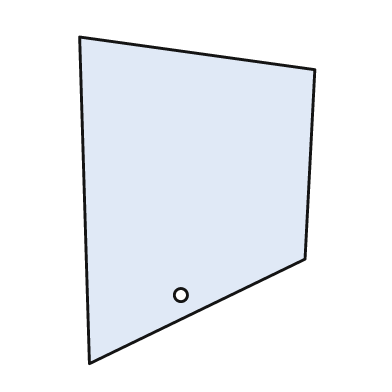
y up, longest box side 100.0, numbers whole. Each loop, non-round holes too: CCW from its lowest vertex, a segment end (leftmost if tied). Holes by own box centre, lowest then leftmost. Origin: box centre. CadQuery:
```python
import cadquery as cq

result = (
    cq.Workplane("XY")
    .moveTo(-33.0, -50.0)
    .lineTo(33.0, -18.0)
    .lineTo(36.0, 40.0)
    .lineTo(-36.0, 50.0)
    .close()
    .moveTo(-5.0, -29.0)
    .circle(2.0)
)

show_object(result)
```